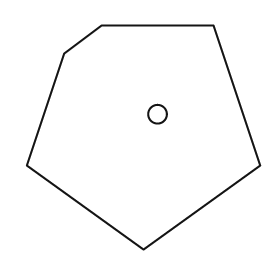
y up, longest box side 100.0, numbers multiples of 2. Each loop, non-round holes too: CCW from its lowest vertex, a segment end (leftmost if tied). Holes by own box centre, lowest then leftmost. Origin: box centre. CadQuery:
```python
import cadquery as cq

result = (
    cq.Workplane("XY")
    .moveTo(0.0, -48.0)
    .lineTo(50.0, -12.0)
    .lineTo(30.0, 48.0)
    .lineTo(-18.0, 48.0)
    .lineTo(-34.0, 36.0)
    .lineTo(-50.0, -12.0)
    .close()
    .moveTo(6.0, 10.0)
    .circle(4.0)
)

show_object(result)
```